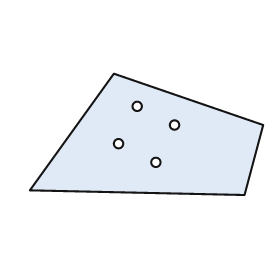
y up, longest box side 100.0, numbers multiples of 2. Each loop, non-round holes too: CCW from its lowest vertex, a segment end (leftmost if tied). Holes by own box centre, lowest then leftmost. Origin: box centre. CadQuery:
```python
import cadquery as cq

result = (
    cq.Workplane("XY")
    .moveTo(42.0, -26.0)
    .lineTo(50.0, 4.0)
    .lineTo(-14.0, 26.0)
    .lineTo(-50.0, -24.0)
    .close()
    .moveTo(4.0, -12.0)
    .circle(2.0)
    .moveTo(-12.0, -4.0)
    .circle(2.0)
    .moveTo(12.0, 4.0)
    .circle(2.0)
    .moveTo(-4.0, 12.0)
    .circle(2.0)
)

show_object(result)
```